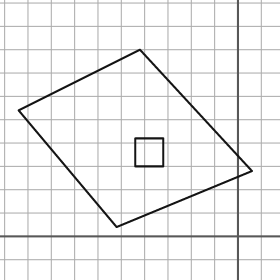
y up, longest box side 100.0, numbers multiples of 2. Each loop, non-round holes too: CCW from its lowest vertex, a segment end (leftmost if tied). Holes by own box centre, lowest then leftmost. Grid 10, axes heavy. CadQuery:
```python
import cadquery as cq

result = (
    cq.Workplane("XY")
    .moveTo(-52.0, 4.0)
    .lineTo(6.0, 28.0)
    .lineTo(-42.0, 80.0)
    .lineTo(-94.0, 54.0)
    .close()
    .moveTo(-44.0, 30.0)
    .lineTo(-32.0, 30.0)
    .lineTo(-32.0, 42.0)
    .lineTo(-44.0, 42.0)
    .close()
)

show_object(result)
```